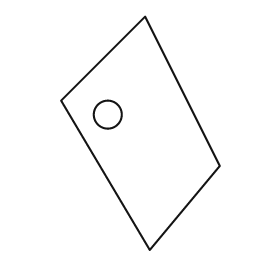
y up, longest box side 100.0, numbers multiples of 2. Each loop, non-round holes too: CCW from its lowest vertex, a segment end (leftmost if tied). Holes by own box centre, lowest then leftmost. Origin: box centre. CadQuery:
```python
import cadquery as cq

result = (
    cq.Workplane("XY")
    .moveTo(4.0, -50.0)
    .lineTo(34.0, -14.0)
    .lineTo(2.0, 50.0)
    .lineTo(-34.0, 14.0)
    .close()
    .moveTo(-14.0, 8.0)
    .circle(6.0)
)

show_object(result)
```